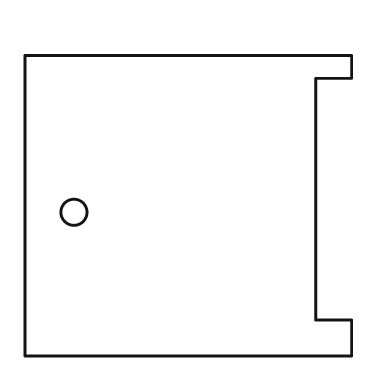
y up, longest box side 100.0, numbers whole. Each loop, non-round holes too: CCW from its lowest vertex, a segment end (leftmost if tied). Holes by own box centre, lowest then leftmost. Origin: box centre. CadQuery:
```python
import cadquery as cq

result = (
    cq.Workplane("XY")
    .moveTo(-50.0, -46.0)
    .lineTo(50.0, -46.0)
    .lineTo(50.0, -35.0)
    .lineTo(39.0, -35.0)
    .lineTo(39.0, 39.0)
    .lineTo(50.0, 39.0)
    .lineTo(50.0, 46.0)
    .lineTo(-50.0, 46.0)
    .close()
    .moveTo(-35.0, -2.0)
    .circle(4.0)
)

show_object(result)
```